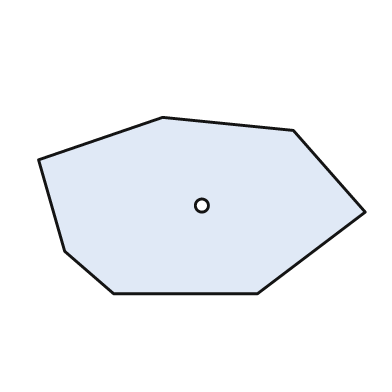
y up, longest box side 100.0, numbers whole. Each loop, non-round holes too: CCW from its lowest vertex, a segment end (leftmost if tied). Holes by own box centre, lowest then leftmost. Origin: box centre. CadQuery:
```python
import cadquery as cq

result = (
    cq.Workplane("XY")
    .moveTo(-27.0, -27.0)
    .lineTo(17.0, -27.0)
    .lineTo(50.0, -2.0)
    .lineTo(28.0, 23.0)
    .lineTo(-12.0, 27.0)
    .lineTo(-50.0, 14.0)
    .lineTo(-42.0, -14.0)
    .close()
    .moveTo(0.0, 0.0)
    .circle(2.0)
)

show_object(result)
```